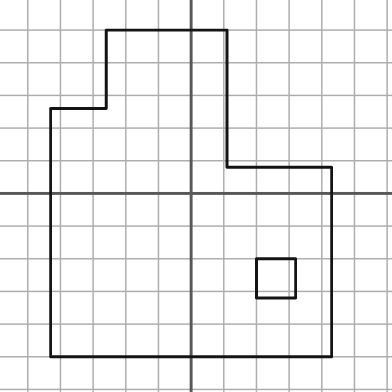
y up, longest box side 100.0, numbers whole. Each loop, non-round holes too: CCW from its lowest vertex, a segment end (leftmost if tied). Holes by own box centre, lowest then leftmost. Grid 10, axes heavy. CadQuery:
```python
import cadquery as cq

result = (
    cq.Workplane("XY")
    .moveTo(-43.0, -50.0)
    .lineTo(43.0, -50.0)
    .lineTo(43.0, 8.0)
    .lineTo(11.0, 8.0)
    .lineTo(11.0, 50.0)
    .lineTo(-26.0, 50.0)
    .lineTo(-26.0, 26.0)
    .lineTo(-43.0, 26.0)
    .close()
    .moveTo(20.0, -32.0)
    .lineTo(32.0, -32.0)
    .lineTo(32.0, -20.0)
    .lineTo(20.0, -20.0)
    .close()
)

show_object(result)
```